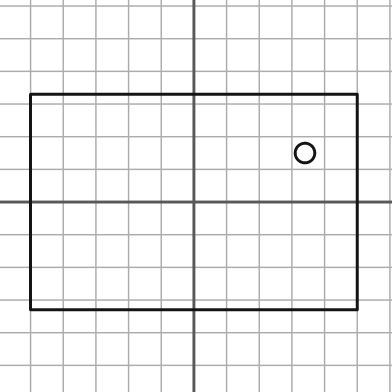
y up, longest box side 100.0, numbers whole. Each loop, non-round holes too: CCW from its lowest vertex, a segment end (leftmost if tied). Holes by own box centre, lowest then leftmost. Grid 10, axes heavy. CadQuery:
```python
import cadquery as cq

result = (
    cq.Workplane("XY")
    .moveTo(-50.0, -33.0)
    .lineTo(50.0, -33.0)
    .lineTo(50.0, 33.0)
    .lineTo(-50.0, 33.0)
    .close()
    .moveTo(34.0, 15.0)
    .circle(3.0)
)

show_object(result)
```